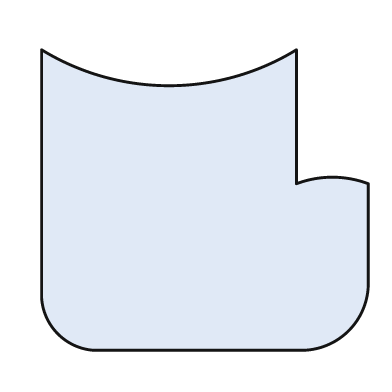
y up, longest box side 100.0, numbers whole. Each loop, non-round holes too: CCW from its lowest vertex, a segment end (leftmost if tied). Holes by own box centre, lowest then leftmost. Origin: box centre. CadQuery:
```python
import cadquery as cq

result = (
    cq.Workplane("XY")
    .moveTo(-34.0, -46.0)
    .lineTo(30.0, -46.0)
    .threePointArc((44.0, -40.0), (50.0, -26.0))
    .lineTo(50.0, 5.0)
    .threePointArc((39.0, 7.0), (28.0, 5.0))
    .lineTo(28.0, 46.0)
    .threePointArc((-11.0, 35.0), (-50.0, 46.0))
    .lineTo(-50.0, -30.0)
    .threePointArc((-45.0, -41.0), (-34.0, -46.0))
    .close()
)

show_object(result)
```